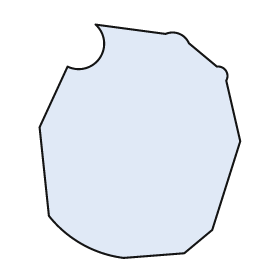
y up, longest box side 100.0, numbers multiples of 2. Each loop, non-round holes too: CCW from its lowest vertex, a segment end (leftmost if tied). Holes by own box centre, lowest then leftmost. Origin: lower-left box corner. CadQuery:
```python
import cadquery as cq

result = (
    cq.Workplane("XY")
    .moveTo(36.0, 0.0)
    .lineTo(62.0, 2.0)
    .lineTo(74.0, 12.0)
    .lineTo(86.0, 50.0)
    .lineTo(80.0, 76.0)
    .threePointArc((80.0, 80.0), (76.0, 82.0))
    .lineTo(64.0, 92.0)
    .threePointArc((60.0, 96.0), (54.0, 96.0))
    .lineTo(24.0, 100.0)
    .threePointArc((26.0, 86.0), (12.0, 82.0))
    .lineTo(0.0, 56.0)
    .lineTo(4.0, 18.0)
    .threePointArc((18.0, 6.0), (36.0, 0.0))
    .close()
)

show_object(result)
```